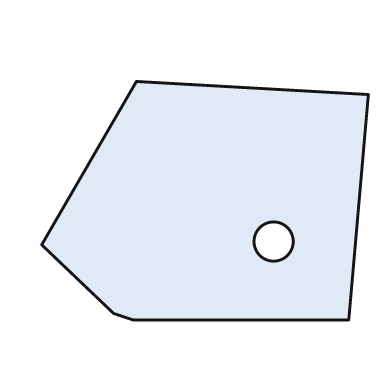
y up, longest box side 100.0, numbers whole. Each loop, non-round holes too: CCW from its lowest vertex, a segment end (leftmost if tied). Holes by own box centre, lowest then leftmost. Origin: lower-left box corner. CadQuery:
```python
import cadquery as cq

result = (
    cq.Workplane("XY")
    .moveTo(28.0, 0.0)
    .lineTo(94.0, 0.0)
    .lineTo(100.0, 69.0)
    .lineTo(29.0, 73.0)
    .lineTo(0.0, 23.0)
    .lineTo(22.0, 2.0)
    .close()
    .moveTo(71.0, 24.0)
    .circle(6.0)
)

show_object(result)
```